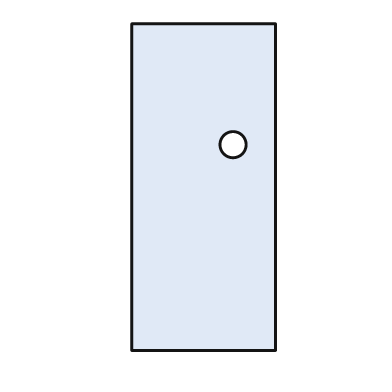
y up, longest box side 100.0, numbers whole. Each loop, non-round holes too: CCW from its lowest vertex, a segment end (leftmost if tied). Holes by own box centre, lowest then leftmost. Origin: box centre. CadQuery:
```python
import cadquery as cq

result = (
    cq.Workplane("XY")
    .moveTo(-22.0, -50.0)
    .lineTo(22.0, -50.0)
    .lineTo(22.0, 50.0)
    .lineTo(-22.0, 50.0)
    .close()
    .moveTo(9.0, 13.0)
    .circle(4.0)
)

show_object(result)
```